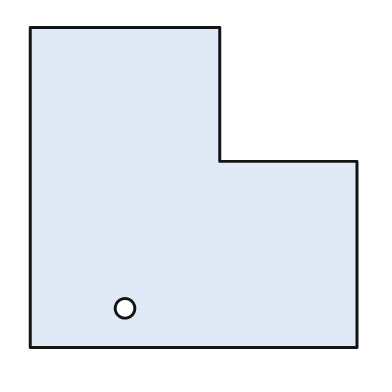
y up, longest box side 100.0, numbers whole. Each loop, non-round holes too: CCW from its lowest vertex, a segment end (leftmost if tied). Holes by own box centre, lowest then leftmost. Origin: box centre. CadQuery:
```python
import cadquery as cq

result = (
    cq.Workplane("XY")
    .moveTo(-50.0, -49.0)
    .lineTo(50.0, -49.0)
    .lineTo(50.0, 8.0)
    .lineTo(8.0, 8.0)
    .lineTo(8.0, 49.0)
    .lineTo(-50.0, 49.0)
    .close()
    .moveTo(-21.0, -37.0)
    .circle(3.0)
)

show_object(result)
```